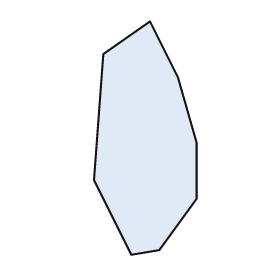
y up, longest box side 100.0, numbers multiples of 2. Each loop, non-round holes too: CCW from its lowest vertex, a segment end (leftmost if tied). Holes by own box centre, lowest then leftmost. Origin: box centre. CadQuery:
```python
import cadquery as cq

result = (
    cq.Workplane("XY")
    .moveTo(-6.0, -50.0)
    .lineTo(6.0, -48.0)
    .lineTo(22.0, -26.0)
    .lineTo(22.0, -2.0)
    .lineTo(14.0, 26.0)
    .lineTo(2.0, 50.0)
    .lineTo(-18.0, 36.0)
    .lineTo(-22.0, -18.0)
    .close()
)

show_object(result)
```